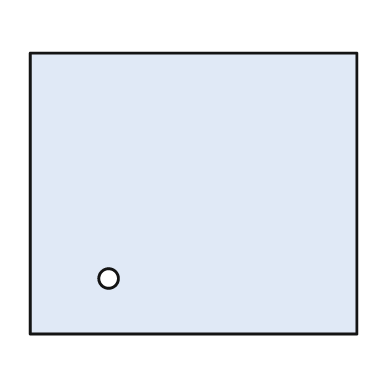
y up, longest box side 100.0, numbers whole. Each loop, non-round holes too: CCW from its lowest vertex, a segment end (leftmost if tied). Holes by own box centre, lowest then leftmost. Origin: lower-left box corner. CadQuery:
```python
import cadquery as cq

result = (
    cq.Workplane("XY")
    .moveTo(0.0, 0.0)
    .lineTo(100.0, 0.0)
    .lineTo(100.0, 86.0)
    .lineTo(0.0, 86.0)
    .close()
    .moveTo(24.0, 17.0)
    .circle(3.0)
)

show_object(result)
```